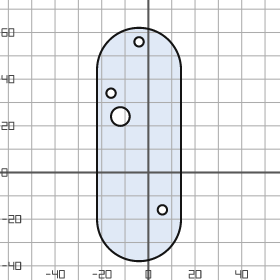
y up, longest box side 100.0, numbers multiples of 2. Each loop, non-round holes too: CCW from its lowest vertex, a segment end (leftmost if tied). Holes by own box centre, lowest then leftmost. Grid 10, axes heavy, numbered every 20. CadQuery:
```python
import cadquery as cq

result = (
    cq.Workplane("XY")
    .moveTo(-22.0, -20.0)
    .threePointArc((-4.0, -38.0), (14.0, -20.0))
    .lineTo(14.0, 44.0)
    .threePointArc((-4.0, 62.0), (-22.0, 44.0))
    .close()
    .moveTo(6.0, -16.0)
    .circle(2.0)
    .moveTo(-12.0, 24.0)
    .circle(4.0)
    .moveTo(-16.0, 34.0)
    .circle(2.0)
    .moveTo(-4.0, 56.0)
    .circle(2.0)
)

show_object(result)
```